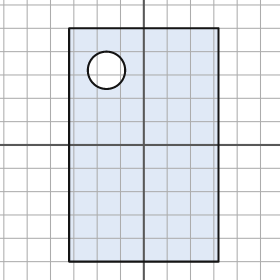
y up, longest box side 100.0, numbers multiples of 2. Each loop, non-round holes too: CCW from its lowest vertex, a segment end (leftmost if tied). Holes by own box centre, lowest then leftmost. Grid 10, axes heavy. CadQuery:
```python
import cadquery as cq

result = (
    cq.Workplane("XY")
    .moveTo(-32.0, -50.0)
    .lineTo(32.0, -50.0)
    .lineTo(32.0, 50.0)
    .lineTo(-32.0, 50.0)
    .close()
    .moveTo(-16.0, 32.0)
    .circle(8.0)
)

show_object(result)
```